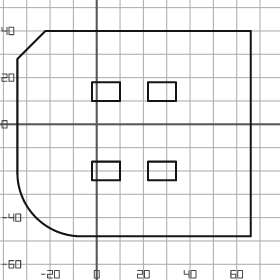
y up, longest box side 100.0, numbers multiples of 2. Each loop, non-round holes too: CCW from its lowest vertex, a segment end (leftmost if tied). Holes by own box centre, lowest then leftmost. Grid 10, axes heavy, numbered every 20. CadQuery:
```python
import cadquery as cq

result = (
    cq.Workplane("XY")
    .moveTo(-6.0, -48.0)
    .lineTo(66.0, -48.0)
    .lineTo(66.0, 40.0)
    .lineTo(-22.0, 40.0)
    .lineTo(-34.0, 28.0)
    .lineTo(-34.0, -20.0)
    .threePointArc((-26.0, -40.0), (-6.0, -48.0))
    .close()
    .moveTo(-2.0, -24.0)
    .lineTo(10.0, -24.0)
    .lineTo(10.0, -16.0)
    .lineTo(-2.0, -16.0)
    .close()
    .moveTo(22.0, -24.0)
    .lineTo(34.0, -24.0)
    .lineTo(34.0, -16.0)
    .lineTo(22.0, -16.0)
    .close()
    .moveTo(-2.0, 10.0)
    .lineTo(10.0, 10.0)
    .lineTo(10.0, 18.0)
    .lineTo(-2.0, 18.0)
    .close()
    .moveTo(22.0, 10.0)
    .lineTo(34.0, 10.0)
    .lineTo(34.0, 18.0)
    .lineTo(22.0, 18.0)
    .close()
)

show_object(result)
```